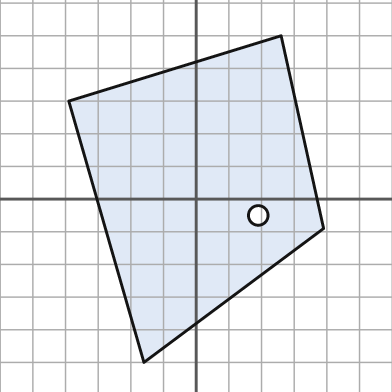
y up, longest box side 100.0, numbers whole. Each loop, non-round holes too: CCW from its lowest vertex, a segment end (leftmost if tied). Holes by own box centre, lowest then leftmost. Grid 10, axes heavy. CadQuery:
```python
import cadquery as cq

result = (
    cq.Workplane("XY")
    .moveTo(-16.0, -50.0)
    .lineTo(39.0, -9.0)
    .lineTo(26.0, 50.0)
    .lineTo(-39.0, 30.0)
    .close()
    .moveTo(19.0, -5.0)
    .circle(3.0)
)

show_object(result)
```